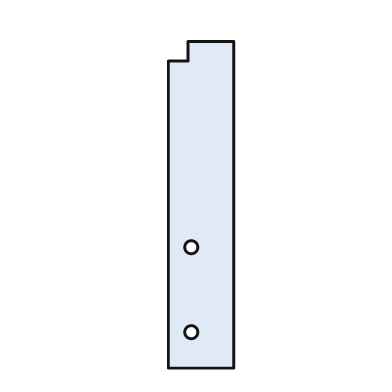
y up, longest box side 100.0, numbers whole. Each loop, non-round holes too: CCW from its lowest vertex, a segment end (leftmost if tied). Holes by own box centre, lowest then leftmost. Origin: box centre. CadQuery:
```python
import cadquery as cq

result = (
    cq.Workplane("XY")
    .moveTo(-10.0, -50.0)
    .lineTo(10.0, -50.0)
    .lineTo(10.0, 50.0)
    .lineTo(-4.0, 50.0)
    .lineTo(-4.0, 44.0)
    .lineTo(-10.0, 44.0)
    .close()
    .moveTo(-3.0, -39.0)
    .circle(2.0)
    .moveTo(-3.0, -13.0)
    .circle(2.0)
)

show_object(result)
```